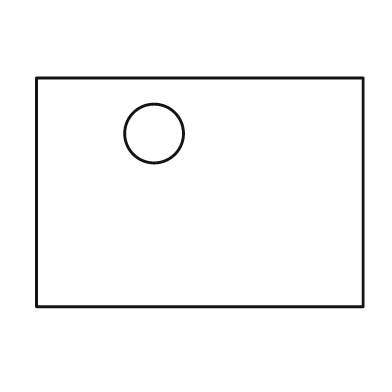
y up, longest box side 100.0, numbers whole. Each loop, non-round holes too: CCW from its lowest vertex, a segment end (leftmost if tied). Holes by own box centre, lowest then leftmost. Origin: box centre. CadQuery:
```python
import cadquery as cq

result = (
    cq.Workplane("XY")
    .moveTo(-50.0, -35.0)
    .lineTo(50.0, -35.0)
    .lineTo(50.0, 35.0)
    .lineTo(-50.0, 35.0)
    .close()
    .moveTo(-14.0, 18.0)
    .circle(9.0)
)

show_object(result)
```